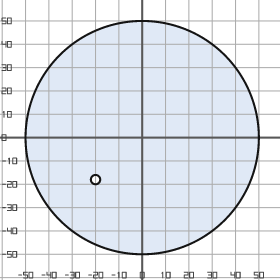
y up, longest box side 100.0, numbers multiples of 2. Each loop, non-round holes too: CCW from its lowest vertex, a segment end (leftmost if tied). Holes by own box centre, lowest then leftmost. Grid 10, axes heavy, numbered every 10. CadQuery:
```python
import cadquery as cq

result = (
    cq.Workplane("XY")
    .moveTo(0.0, 0.0)
    .circle(50.0)
    .moveTo(-20.0, -18.0)
    .circle(2.0)
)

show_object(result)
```